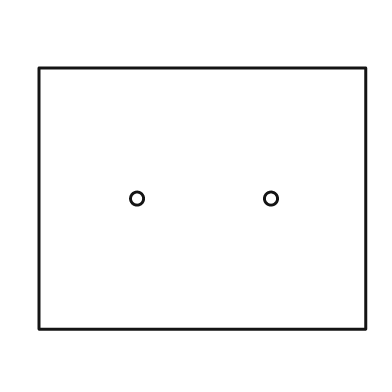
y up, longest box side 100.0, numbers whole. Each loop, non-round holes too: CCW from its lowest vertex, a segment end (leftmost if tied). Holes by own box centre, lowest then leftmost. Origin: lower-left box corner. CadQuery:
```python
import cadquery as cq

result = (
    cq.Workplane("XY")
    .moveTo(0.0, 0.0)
    .lineTo(100.0, 0.0)
    .lineTo(100.0, 80.0)
    .lineTo(0.0, 80.0)
    .close()
    .moveTo(30.0, 40.0)
    .circle(2.0)
    .moveTo(71.0, 40.0)
    .circle(2.0)
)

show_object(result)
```